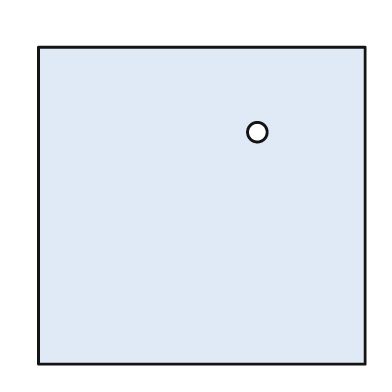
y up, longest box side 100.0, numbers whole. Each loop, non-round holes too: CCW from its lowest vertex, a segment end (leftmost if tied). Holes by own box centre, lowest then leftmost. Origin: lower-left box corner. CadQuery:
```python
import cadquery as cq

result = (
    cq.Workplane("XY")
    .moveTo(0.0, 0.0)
    .lineTo(100.0, 0.0)
    .lineTo(100.0, 97.0)
    .lineTo(0.0, 97.0)
    .close()
    .moveTo(67.0, 71.0)
    .circle(3.0)
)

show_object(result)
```